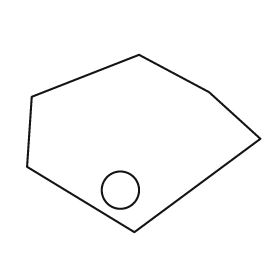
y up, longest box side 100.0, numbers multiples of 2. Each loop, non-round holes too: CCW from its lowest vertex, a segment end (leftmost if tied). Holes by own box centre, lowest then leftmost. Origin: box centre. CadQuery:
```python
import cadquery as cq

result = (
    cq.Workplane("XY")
    .moveTo(-4.0, -38.0)
    .lineTo(50.0, 2.0)
    .lineTo(28.0, 22.0)
    .lineTo(-2.0, 38.0)
    .lineTo(-48.0, 20.0)
    .lineTo(-50.0, -10.0)
    .close()
    .moveTo(-10.0, -20.0)
    .circle(8.0)
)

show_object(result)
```